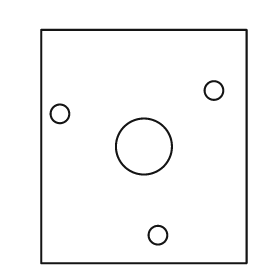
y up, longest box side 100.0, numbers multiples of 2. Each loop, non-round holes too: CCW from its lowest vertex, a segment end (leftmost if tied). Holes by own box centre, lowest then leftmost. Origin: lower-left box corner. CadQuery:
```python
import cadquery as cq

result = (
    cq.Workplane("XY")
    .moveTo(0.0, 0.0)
    .lineTo(88.0, 0.0)
    .lineTo(88.0, 100.0)
    .lineTo(0.0, 100.0)
    .close()
    .moveTo(50.0, 12.0)
    .circle(4.0)
    .moveTo(44.0, 50.0)
    .circle(12.0)
    .moveTo(8.0, 64.0)
    .circle(4.0)
    .moveTo(74.0, 74.0)
    .circle(4.0)
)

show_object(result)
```